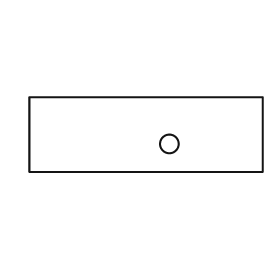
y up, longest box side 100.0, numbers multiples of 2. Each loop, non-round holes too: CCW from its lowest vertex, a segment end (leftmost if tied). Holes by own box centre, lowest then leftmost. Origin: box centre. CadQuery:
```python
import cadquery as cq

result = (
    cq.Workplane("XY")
    .moveTo(-50.0, -16.0)
    .lineTo(50.0, -16.0)
    .lineTo(50.0, 16.0)
    .lineTo(-50.0, 16.0)
    .close()
    .moveTo(10.0, -4.0)
    .circle(4.0)
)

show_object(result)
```